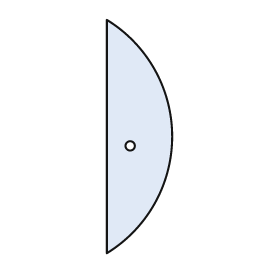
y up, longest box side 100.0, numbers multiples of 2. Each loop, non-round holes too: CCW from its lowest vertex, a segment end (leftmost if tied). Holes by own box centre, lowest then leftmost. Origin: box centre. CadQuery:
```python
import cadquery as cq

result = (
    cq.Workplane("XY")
    .moveTo(-14.0, -50.0)
    .threePointArc((14.0, 0.0), (-14.0, 50.0))
    .close()
    .moveTo(-4.0, -4.0)
    .circle(2.0)
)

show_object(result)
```